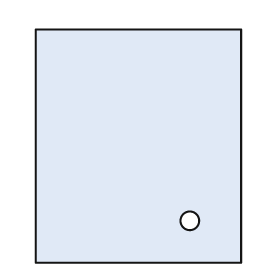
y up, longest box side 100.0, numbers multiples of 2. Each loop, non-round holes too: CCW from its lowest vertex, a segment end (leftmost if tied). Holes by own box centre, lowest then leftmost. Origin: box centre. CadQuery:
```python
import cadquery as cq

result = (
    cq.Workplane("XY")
    .moveTo(-44.0, -50.0)
    .lineTo(44.0, -50.0)
    .lineTo(44.0, 50.0)
    .lineTo(-44.0, 50.0)
    .close()
    .moveTo(22.0, -32.0)
    .circle(4.0)
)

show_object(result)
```